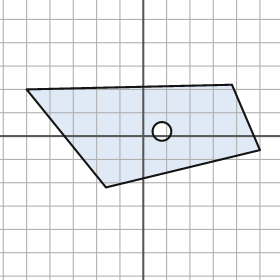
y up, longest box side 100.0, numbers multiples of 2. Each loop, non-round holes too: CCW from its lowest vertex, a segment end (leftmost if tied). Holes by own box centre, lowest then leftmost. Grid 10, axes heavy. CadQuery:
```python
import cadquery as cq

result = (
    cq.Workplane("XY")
    .moveTo(-16.0, -22.0)
    .lineTo(50.0, -6.0)
    .lineTo(38.0, 22.0)
    .lineTo(-50.0, 20.0)
    .close()
    .moveTo(8.0, 2.0)
    .circle(4.0)
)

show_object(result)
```